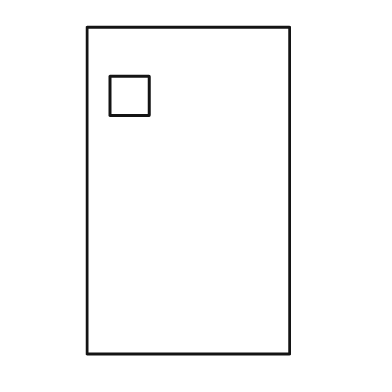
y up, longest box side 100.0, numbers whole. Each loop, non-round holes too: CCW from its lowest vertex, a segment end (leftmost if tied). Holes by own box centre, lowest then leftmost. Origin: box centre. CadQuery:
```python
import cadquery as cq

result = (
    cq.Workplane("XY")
    .moveTo(-31.0, -50.0)
    .lineTo(31.0, -50.0)
    .lineTo(31.0, 50.0)
    .lineTo(-31.0, 50.0)
    .close()
    .moveTo(-24.0, 23.0)
    .lineTo(-12.0, 23.0)
    .lineTo(-12.0, 35.0)
    .lineTo(-24.0, 35.0)
    .close()
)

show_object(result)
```